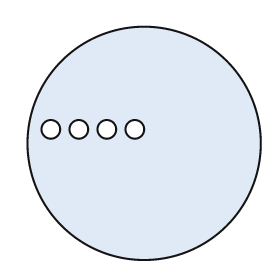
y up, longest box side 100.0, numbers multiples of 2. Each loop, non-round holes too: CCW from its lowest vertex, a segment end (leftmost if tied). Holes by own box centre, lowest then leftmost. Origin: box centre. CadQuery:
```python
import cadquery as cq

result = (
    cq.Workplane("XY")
    .moveTo(0.0, 0.0)
    .circle(50.0)
    .moveTo(-40.0, 6.0)
    .circle(4.0)
    .moveTo(-28.0, 6.0)
    .circle(4.0)
    .moveTo(-16.0, 6.0)
    .circle(4.0)
    .moveTo(-4.0, 6.0)
    .circle(4.0)
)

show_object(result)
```